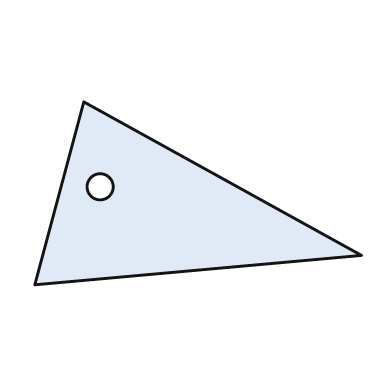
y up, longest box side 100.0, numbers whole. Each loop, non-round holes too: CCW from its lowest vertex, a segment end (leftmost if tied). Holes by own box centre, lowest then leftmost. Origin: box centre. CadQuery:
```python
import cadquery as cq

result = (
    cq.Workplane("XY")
    .moveTo(-50.0, -28.0)
    .lineTo(50.0, -19.0)
    .lineTo(-35.0, 28.0)
    .close()
    .moveTo(-30.0, 2.0)
    .circle(4.0)
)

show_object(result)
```